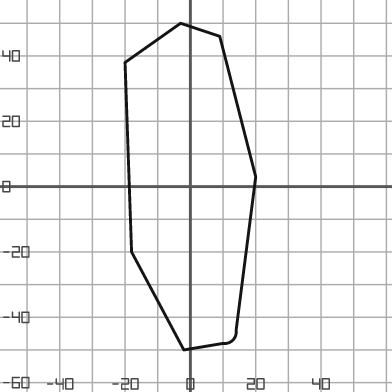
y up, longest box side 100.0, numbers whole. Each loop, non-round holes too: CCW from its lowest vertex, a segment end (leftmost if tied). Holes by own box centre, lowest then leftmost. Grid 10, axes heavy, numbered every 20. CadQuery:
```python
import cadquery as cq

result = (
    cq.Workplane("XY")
    .moveTo(-2.0, -50.0)
    .lineTo(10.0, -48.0)
    .threePointArc((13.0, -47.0), (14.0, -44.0))
    .lineTo(20.0, 3.0)
    .lineTo(9.0, 46.0)
    .lineTo(-3.0, 50.0)
    .lineTo(-20.0, 38.0)
    .lineTo(-18.0, -20.0)
    .close()
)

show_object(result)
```